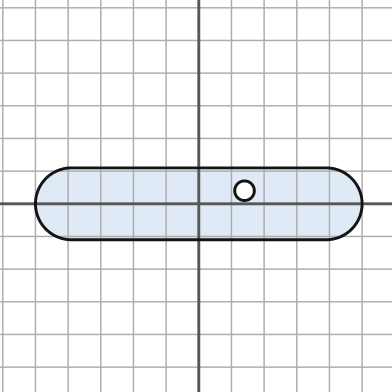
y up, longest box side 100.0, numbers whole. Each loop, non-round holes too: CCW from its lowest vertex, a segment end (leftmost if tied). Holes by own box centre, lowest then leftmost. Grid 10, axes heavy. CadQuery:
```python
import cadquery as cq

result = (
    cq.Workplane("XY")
    .moveTo(-39.0, -11.0)
    .lineTo(39.0, -11.0)
    .threePointArc((50.0, 0.0), (39.0, 11.0))
    .lineTo(-39.0, 11.0)
    .threePointArc((-50.0, 0.0), (-39.0, -11.0))
    .close()
    .moveTo(14.0, 4.0)
    .circle(3.0)
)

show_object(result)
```